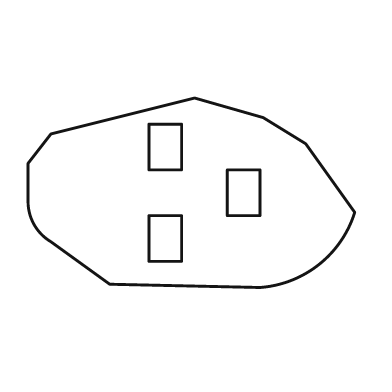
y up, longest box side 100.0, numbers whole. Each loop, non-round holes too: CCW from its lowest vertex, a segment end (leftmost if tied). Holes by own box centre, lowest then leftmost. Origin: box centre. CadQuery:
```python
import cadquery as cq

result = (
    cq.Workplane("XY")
    .moveTo(21.0, -29.0)
    .threePointArc((39.0, -22.0), (50.0, -6.0))
    .lineTo(35.0, 15.0)
    .lineTo(22.0, 23.0)
    .lineTo(1.0, 29.0)
    .lineTo(-43.0, 18.0)
    .lineTo(-50.0, 9.0)
    .lineTo(-50.0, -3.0)
    .threePointArc((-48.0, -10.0), (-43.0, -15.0))
    .lineTo(-25.0, -28.0)
    .close()
    .moveTo(-13.0, -21.0)
    .lineTo(-3.0, -21.0)
    .lineTo(-3.0, -7.0)
    .lineTo(-13.0, -7.0)
    .close()
    .moveTo(11.0, -7.0)
    .lineTo(21.0, -7.0)
    .lineTo(21.0, 7.0)
    .lineTo(11.0, 7.0)
    .close()
    .moveTo(-13.0, 7.0)
    .lineTo(-3.0, 7.0)
    .lineTo(-3.0, 21.0)
    .lineTo(-13.0, 21.0)
    .close()
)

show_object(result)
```